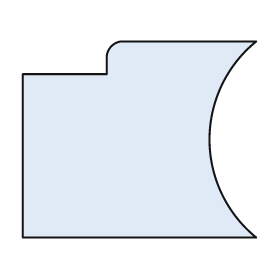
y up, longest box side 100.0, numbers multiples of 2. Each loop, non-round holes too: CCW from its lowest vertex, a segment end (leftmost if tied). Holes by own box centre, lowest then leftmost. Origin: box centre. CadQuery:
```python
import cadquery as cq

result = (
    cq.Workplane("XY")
    .moveTo(-50.0, -42.0)
    .lineTo(50.0, -42.0)
    .threePointArc((30.0, 0.0), (50.0, 42.0))
    .lineTo(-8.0, 42.0)
    .threePointArc((-12.0, 40.0), (-14.0, 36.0))
    .lineTo(-14.0, 28.0)
    .lineTo(-50.0, 28.0)
    .close()
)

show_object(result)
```